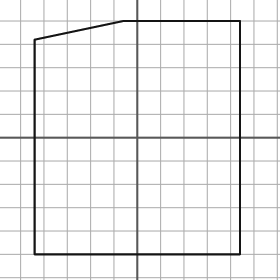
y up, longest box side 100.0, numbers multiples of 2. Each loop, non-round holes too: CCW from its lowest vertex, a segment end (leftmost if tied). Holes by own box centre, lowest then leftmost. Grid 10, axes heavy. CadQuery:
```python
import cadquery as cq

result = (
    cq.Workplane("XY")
    .moveTo(-44.0, -50.0)
    .lineTo(44.0, -50.0)
    .lineTo(44.0, 50.0)
    .lineTo(-6.0, 50.0)
    .lineTo(-44.0, 42.0)
    .close()
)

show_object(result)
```